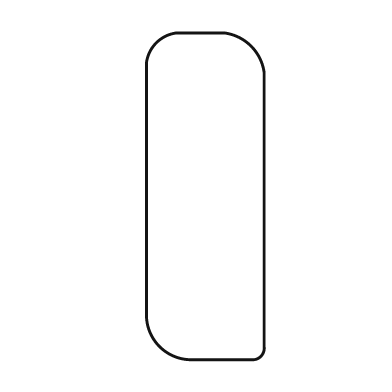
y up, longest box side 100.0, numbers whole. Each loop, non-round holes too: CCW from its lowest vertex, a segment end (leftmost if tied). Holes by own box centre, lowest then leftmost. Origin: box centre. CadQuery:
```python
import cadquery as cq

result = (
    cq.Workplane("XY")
    .moveTo(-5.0, -50.0)
    .lineTo(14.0, -50.0)
    .threePointArc((17.0, -49.0), (18.0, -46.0))
    .lineTo(18.0, 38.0)
    .threePointArc((14.0, 46.0), (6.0, 50.0))
    .lineTo(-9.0, 50.0)
    .threePointArc((-15.0, 47.0), (-18.0, 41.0))
    .lineTo(-18.0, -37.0)
    .threePointArc((-14.0, -46.0), (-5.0, -50.0))
    .close()
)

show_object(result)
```